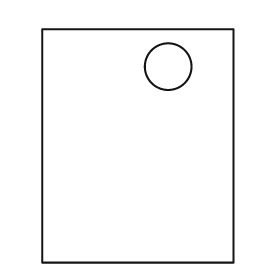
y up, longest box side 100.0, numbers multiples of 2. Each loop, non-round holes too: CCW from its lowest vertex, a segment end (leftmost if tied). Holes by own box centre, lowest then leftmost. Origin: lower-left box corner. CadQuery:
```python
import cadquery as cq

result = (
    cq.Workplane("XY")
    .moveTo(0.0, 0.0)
    .lineTo(82.0, 0.0)
    .lineTo(82.0, 100.0)
    .lineTo(0.0, 100.0)
    .close()
    .moveTo(54.0, 84.0)
    .circle(10.0)
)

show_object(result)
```